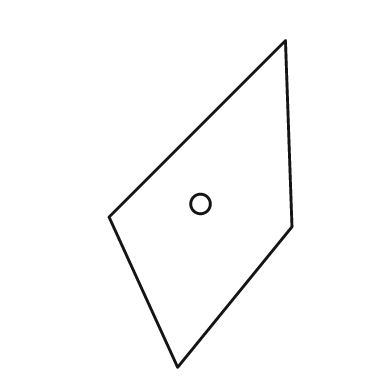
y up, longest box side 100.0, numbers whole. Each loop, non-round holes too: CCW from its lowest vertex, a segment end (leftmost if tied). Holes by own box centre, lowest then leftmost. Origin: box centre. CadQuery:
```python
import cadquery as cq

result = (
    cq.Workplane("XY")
    .moveTo(-7.0, -50.0)
    .lineTo(28.0, -7.0)
    .lineTo(26.0, 50.0)
    .lineTo(-28.0, -4.0)
    .close()
    .moveTo(0.0, 0.0)
    .circle(3.0)
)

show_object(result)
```